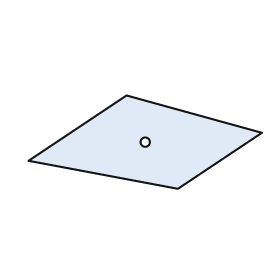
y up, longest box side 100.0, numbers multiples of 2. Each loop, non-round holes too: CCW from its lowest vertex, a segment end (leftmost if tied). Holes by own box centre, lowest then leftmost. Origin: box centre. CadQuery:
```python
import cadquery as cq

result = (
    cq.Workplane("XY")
    .moveTo(14.0, -20.0)
    .lineTo(50.0, 4.0)
    .lineTo(-8.0, 20.0)
    .lineTo(-50.0, -8.0)
    .close()
    .moveTo(0.0, 0.0)
    .circle(2.0)
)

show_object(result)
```